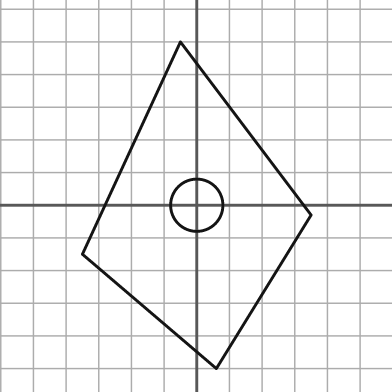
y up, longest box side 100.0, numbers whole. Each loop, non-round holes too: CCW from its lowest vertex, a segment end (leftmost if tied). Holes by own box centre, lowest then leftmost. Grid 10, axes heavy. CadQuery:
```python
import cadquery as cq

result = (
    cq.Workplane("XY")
    .moveTo(6.0, -50.0)
    .lineTo(35.0, -3.0)
    .lineTo(-5.0, 50.0)
    .lineTo(-35.0, -15.0)
    .close()
    .moveTo(0.0, 0.0)
    .circle(8.0)
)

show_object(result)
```